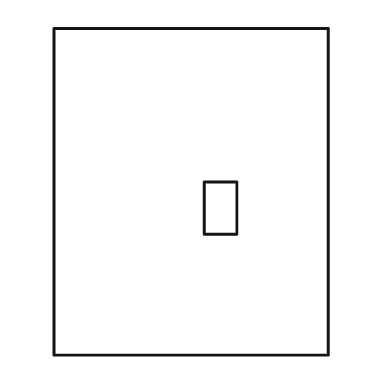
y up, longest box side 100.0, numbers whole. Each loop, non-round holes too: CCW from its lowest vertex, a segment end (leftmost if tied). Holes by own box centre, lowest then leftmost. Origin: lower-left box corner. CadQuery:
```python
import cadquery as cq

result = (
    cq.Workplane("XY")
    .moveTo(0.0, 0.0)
    .lineTo(84.0, 0.0)
    .lineTo(84.0, 100.0)
    .lineTo(0.0, 100.0)
    .close()
    .moveTo(46.0, 37.0)
    .lineTo(56.0, 37.0)
    .lineTo(56.0, 53.0)
    .lineTo(46.0, 53.0)
    .close()
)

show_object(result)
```